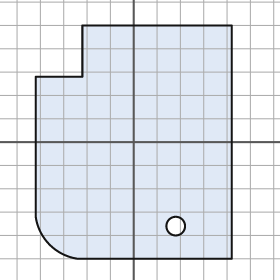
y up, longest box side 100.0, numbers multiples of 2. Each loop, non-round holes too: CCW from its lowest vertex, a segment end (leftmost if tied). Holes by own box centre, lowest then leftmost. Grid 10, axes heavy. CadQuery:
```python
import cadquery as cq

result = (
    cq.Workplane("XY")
    .moveTo(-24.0, -50.0)
    .lineTo(42.0, -50.0)
    .lineTo(42.0, 50.0)
    .lineTo(-22.0, 50.0)
    .lineTo(-22.0, 28.0)
    .lineTo(-42.0, 28.0)
    .lineTo(-42.0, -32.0)
    .threePointArc((-36.0, -44.0), (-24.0, -50.0))
    .close()
    .moveTo(18.0, -36.0)
    .circle(4.0)
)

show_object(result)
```